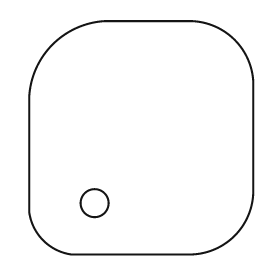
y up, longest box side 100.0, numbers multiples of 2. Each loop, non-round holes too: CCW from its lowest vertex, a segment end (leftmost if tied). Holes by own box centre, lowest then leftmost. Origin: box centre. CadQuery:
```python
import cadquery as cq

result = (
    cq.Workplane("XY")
    .moveTo(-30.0, -50.0)
    .lineTo(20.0, -50.0)
    .threePointArc((40.0, -42.0), (48.0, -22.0))
    .lineTo(48.0, 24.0)
    .threePointArc((40.0, 42.0), (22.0, 50.0))
    .lineTo(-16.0, 50.0)
    .threePointArc((-38.0, 40.0), (-48.0, 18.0))
    .lineTo(-48.0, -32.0)
    .threePointArc((-42.0, -44.0), (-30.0, -50.0))
    .close()
    .moveTo(-20.0, -28.0)
    .circle(6.0)
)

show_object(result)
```